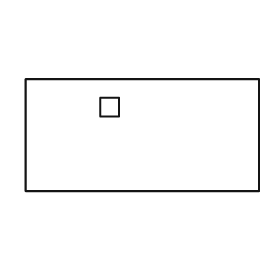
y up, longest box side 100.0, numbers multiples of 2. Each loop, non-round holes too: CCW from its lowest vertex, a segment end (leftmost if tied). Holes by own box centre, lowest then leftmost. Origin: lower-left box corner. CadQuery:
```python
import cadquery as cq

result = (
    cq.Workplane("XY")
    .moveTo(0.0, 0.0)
    .lineTo(100.0, 0.0)
    .lineTo(100.0, 48.0)
    .lineTo(0.0, 48.0)
    .close()
    .moveTo(32.0, 32.0)
    .lineTo(40.0, 32.0)
    .lineTo(40.0, 40.0)
    .lineTo(32.0, 40.0)
    .close()
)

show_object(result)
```